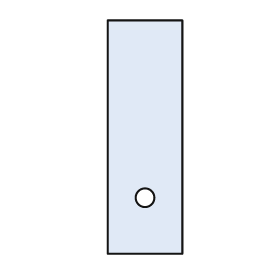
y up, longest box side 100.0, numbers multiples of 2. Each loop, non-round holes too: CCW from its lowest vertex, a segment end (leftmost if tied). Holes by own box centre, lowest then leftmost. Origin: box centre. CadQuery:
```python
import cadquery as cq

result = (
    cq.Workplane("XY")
    .moveTo(-16.0, -50.0)
    .lineTo(16.0, -50.0)
    .lineTo(16.0, 50.0)
    .lineTo(-16.0, 50.0)
    .close()
    .moveTo(0.0, -26.0)
    .circle(4.0)
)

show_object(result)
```